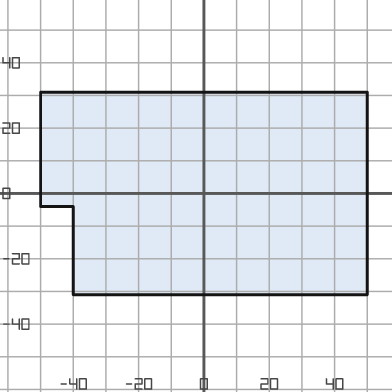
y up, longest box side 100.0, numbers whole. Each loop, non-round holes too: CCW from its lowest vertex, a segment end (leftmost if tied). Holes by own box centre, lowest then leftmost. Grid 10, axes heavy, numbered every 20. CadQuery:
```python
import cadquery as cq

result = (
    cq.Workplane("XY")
    .moveTo(-40.0, -31.0)
    .lineTo(50.0, -31.0)
    .lineTo(50.0, 31.0)
    .lineTo(-50.0, 31.0)
    .lineTo(-50.0, -4.0)
    .lineTo(-40.0, -4.0)
    .close()
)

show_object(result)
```